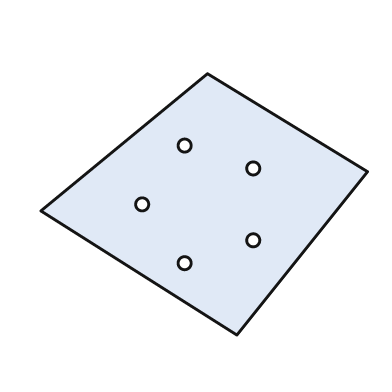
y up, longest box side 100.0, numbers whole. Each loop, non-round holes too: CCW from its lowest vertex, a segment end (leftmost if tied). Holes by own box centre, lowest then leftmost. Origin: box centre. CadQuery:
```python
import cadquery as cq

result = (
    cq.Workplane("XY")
    .moveTo(10.0, -40.0)
    .lineTo(50.0, 10.0)
    .lineTo(1.0, 40.0)
    .lineTo(-50.0, -2.0)
    .close()
    .moveTo(-6.0, -18.0)
    .circle(2.0)
    .moveTo(15.0, -11.0)
    .circle(2.0)
    .moveTo(-19.0, 0.0)
    .circle(2.0)
    .moveTo(15.0, 11.0)
    .circle(2.0)
    .moveTo(-6.0, 18.0)
    .circle(2.0)
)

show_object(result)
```